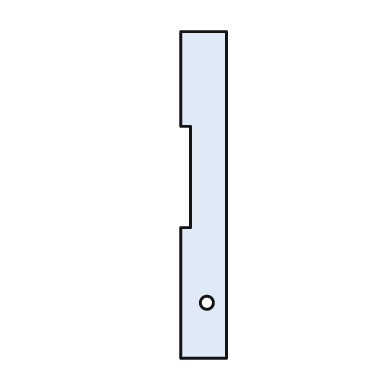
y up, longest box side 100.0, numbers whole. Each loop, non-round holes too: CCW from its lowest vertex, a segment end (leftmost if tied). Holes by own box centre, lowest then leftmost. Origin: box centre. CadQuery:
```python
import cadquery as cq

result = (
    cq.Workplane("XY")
    .moveTo(-7.0, -50.0)
    .lineTo(7.0, -50.0)
    .lineTo(7.0, 50.0)
    .lineTo(-7.0, 50.0)
    .lineTo(-7.0, 21.0)
    .lineTo(-4.0, 21.0)
    .lineTo(-4.0, -10.0)
    .lineTo(-7.0, -10.0)
    .close()
    .moveTo(1.0, -33.0)
    .circle(2.0)
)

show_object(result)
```